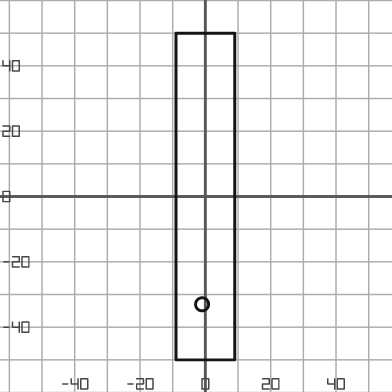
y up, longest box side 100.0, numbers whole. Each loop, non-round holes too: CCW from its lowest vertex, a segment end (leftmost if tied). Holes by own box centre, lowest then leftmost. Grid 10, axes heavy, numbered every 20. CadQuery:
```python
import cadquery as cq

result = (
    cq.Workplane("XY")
    .moveTo(-9.0, -50.0)
    .lineTo(9.0, -50.0)
    .lineTo(9.0, 50.0)
    .lineTo(-9.0, 50.0)
    .close()
    .moveTo(-1.0, -33.0)
    .circle(2.0)
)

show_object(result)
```